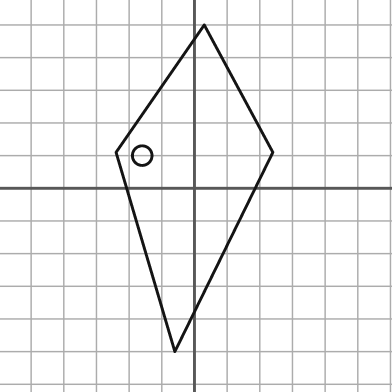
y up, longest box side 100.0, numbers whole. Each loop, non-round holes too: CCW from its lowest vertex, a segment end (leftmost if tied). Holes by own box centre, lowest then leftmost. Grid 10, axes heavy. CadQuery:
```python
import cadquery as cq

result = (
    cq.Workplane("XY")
    .moveTo(-6.0, -50.0)
    .lineTo(24.0, 11.0)
    .lineTo(3.0, 50.0)
    .lineTo(-24.0, 11.0)
    .close()
    .moveTo(-16.0, 10.0)
    .circle(3.0)
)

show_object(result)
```